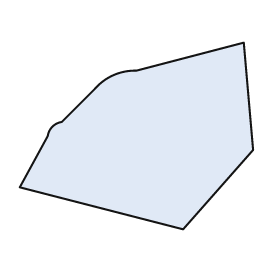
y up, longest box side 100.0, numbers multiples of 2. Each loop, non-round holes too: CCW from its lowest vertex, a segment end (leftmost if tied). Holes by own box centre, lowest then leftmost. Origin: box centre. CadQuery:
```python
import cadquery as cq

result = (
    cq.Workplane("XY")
    .moveTo(20.0, -40.0)
    .lineTo(50.0, -6.0)
    .lineTo(46.0, 40.0)
    .lineTo(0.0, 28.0)
    .threePointArc((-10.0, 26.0), (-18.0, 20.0))
    .lineTo(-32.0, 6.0)
    .threePointArc((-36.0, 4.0), (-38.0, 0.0))
    .lineTo(-50.0, -22.0)
    .close()
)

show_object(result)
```